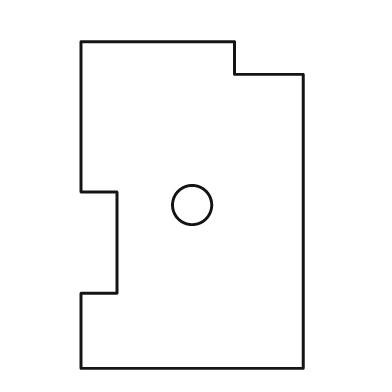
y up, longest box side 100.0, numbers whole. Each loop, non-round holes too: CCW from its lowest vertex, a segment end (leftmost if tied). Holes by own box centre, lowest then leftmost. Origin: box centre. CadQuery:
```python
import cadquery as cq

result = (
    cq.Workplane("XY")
    .moveTo(-34.0, -50.0)
    .lineTo(34.0, -50.0)
    .lineTo(34.0, 40.0)
    .lineTo(13.0, 40.0)
    .lineTo(13.0, 50.0)
    .lineTo(-34.0, 50.0)
    .lineTo(-34.0, 4.0)
    .lineTo(-23.0, 4.0)
    .lineTo(-23.0, -27.0)
    .lineTo(-34.0, -27.0)
    .close()
    .moveTo(0.0, 0.0)
    .circle(6.0)
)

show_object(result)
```